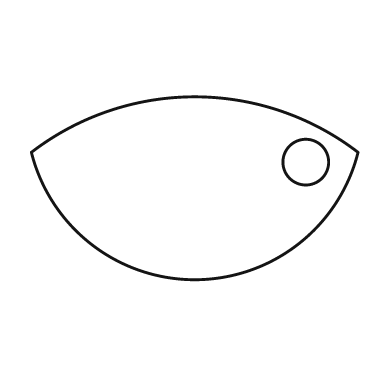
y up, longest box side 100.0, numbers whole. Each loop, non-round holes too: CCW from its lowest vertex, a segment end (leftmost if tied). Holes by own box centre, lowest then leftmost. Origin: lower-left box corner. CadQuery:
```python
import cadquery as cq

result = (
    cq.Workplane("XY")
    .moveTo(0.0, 39.0)
    .threePointArc((50.0, 0.0), (100.0, 39.0))
    .threePointArc((50.0, 56.0), (0.0, 39.0))
    .close()
    .moveTo(84.0, 36.0)
    .circle(7.0)
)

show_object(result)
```